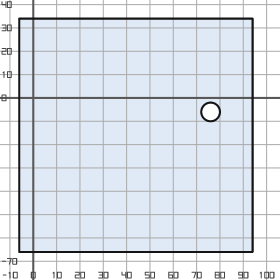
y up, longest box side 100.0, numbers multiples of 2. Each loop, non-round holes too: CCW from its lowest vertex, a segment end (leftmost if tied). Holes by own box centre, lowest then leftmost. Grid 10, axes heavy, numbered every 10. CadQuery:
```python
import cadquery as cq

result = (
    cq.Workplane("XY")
    .moveTo(-6.0, -66.0)
    .lineTo(94.0, -66.0)
    .lineTo(94.0, 34.0)
    .lineTo(-6.0, 34.0)
    .close()
    .moveTo(76.0, -6.0)
    .circle(4.0)
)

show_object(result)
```